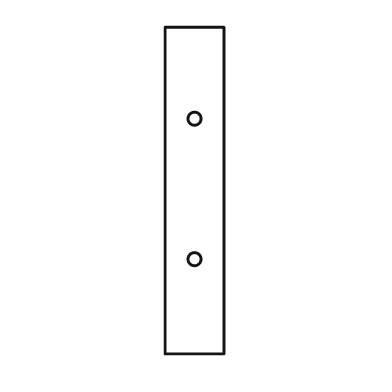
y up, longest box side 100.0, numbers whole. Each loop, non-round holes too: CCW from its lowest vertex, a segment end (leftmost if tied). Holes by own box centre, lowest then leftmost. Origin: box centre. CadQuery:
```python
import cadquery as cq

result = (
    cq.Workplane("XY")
    .moveTo(-9.0, -50.0)
    .lineTo(9.0, -50.0)
    .lineTo(9.0, 50.0)
    .lineTo(-9.0, 50.0)
    .close()
    .moveTo(0.0, -21.0)
    .circle(2.0)
    .moveTo(0.0, 22.0)
    .circle(2.0)
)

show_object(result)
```